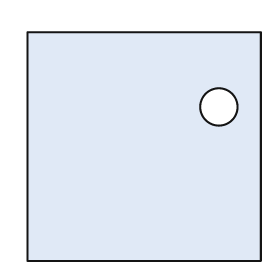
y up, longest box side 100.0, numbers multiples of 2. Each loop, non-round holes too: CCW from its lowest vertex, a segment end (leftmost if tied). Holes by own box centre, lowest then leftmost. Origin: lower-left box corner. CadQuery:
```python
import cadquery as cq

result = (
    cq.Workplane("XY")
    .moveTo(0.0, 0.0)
    .lineTo(100.0, 0.0)
    .lineTo(100.0, 98.0)
    .lineTo(0.0, 98.0)
    .close()
    .moveTo(82.0, 66.0)
    .circle(8.0)
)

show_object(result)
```